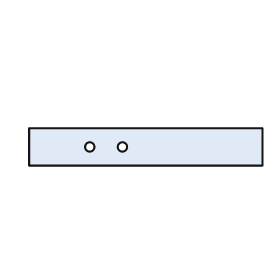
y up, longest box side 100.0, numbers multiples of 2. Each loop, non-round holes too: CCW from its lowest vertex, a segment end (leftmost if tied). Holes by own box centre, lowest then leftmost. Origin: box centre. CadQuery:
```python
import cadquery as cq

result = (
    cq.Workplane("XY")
    .moveTo(-50.0, -8.0)
    .lineTo(50.0, -8.0)
    .lineTo(50.0, 8.0)
    .lineTo(-50.0, 8.0)
    .close()
    .moveTo(-24.0, 0.0)
    .circle(2.0)
    .moveTo(-10.0, 0.0)
    .circle(2.0)
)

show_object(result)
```